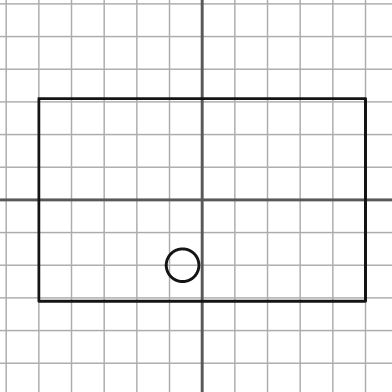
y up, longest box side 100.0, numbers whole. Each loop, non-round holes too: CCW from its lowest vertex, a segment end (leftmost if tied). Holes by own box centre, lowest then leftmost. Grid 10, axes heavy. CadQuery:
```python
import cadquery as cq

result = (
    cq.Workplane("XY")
    .moveTo(-50.0, -31.0)
    .lineTo(50.0, -31.0)
    .lineTo(50.0, 31.0)
    .lineTo(-50.0, 31.0)
    .close()
    .moveTo(-6.0, -20.0)
    .circle(5.0)
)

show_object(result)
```